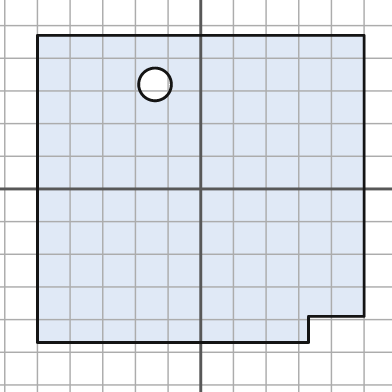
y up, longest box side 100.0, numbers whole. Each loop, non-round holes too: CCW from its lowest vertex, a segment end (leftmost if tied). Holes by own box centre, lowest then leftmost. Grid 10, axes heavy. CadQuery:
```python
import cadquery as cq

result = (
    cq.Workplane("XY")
    .moveTo(-50.0, -47.0)
    .lineTo(33.0, -47.0)
    .lineTo(33.0, -39.0)
    .lineTo(50.0, -39.0)
    .lineTo(50.0, 47.0)
    .lineTo(-50.0, 47.0)
    .close()
    .moveTo(-14.0, 32.0)
    .circle(5.0)
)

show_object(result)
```